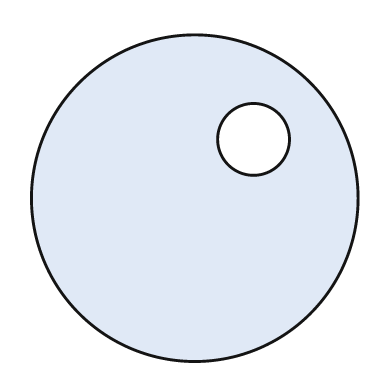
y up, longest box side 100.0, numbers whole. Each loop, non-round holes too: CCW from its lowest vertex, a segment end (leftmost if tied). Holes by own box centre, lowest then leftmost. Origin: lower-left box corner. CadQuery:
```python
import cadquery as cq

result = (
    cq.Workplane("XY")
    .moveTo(50.0, 50.0)
    .circle(50.0)
    .moveTo(68.0, 68.0)
    .circle(11.0)
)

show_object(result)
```